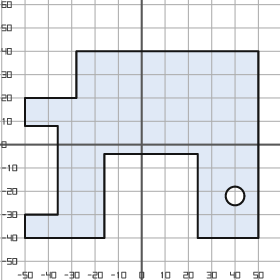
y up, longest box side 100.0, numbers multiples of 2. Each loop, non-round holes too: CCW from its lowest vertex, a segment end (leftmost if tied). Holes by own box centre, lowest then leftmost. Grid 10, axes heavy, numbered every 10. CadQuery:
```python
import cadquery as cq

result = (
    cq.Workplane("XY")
    .moveTo(-50.0, -40.0)
    .lineTo(-16.0, -40.0)
    .lineTo(-16.0, -4.0)
    .lineTo(24.0, -4.0)
    .lineTo(24.0, -40.0)
    .lineTo(50.0, -40.0)
    .lineTo(50.0, 40.0)
    .lineTo(-28.0, 40.0)
    .lineTo(-28.0, 20.0)
    .lineTo(-50.0, 20.0)
    .lineTo(-50.0, 8.0)
    .lineTo(-36.0, 8.0)
    .lineTo(-36.0, -30.0)
    .lineTo(-50.0, -30.0)
    .close()
    .moveTo(40.0, -22.0)
    .circle(4.0)
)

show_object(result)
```